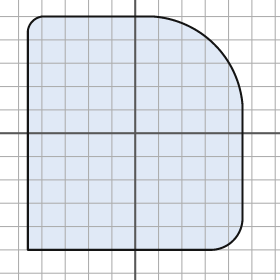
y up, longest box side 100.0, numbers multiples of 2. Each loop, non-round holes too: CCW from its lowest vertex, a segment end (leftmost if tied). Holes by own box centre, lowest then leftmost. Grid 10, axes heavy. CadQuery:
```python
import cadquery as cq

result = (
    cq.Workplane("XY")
    .moveTo(-46.0, -50.0)
    .lineTo(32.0, -50.0)
    .threePointArc((42.0, -46.0), (46.0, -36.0))
    .lineTo(46.0, 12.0)
    .threePointArc((34.0, 38.0), (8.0, 50.0))
    .lineTo(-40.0, 50.0)
    .threePointArc((-44.0, 48.0), (-46.0, 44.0))
    .close()
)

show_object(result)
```